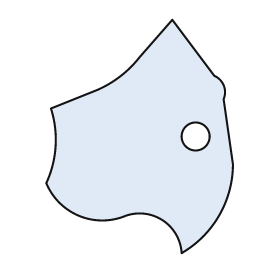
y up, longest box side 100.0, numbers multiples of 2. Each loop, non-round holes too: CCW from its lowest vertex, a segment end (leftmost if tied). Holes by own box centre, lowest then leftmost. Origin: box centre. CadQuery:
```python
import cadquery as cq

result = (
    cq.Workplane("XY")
    .moveTo(18.0, -50.0)
    .threePointArc((34.0, -34.0), (40.0, -12.0))
    .lineTo(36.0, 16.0)
    .threePointArc((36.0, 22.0), (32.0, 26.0))
    .lineTo(14.0, 50.0)
    .lineTo(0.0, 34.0)
    .threePointArc((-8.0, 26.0), (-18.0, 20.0))
    .lineTo(-38.0, 12.0)
    .threePointArc((-36.0, -4.0), (-40.0, -20.0))
    .threePointArc((-26.0, -34.0), (-6.0, -34.0))
    .threePointArc((10.0, -36.0), (18.0, -50.0))
    .close()
    .moveTo(24.0, 0.0)
    .circle(6.0)
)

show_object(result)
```